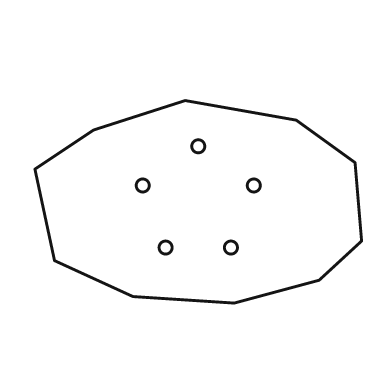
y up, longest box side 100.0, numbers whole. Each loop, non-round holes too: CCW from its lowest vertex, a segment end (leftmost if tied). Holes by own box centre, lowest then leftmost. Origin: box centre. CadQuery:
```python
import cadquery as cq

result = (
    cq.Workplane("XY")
    .moveTo(11.0, -31.0)
    .lineTo(37.0, -24.0)
    .lineTo(50.0, -12.0)
    .lineTo(48.0, 12.0)
    .lineTo(30.0, 25.0)
    .lineTo(-4.0, 31.0)
    .lineTo(-32.0, 22.0)
    .lineTo(-50.0, 10.0)
    .lineTo(-44.0, -18.0)
    .lineTo(-20.0, -29.0)
    .close()
    .moveTo(-10.0, -14.0)
    .circle(2.0)
    .moveTo(10.0, -14.0)
    .circle(2.0)
    .moveTo(-17.0, 5.0)
    .circle(2.0)
    .moveTo(17.0, 5.0)
    .circle(2.0)
    .moveTo(0.0, 17.0)
    .circle(2.0)
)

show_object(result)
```